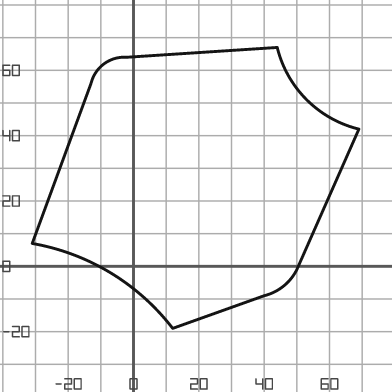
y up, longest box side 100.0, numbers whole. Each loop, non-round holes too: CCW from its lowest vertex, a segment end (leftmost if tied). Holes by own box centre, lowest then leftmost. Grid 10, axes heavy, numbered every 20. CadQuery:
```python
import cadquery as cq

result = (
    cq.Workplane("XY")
    .moveTo(12.0, -19.0)
    .lineTo(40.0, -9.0)
    .threePointArc((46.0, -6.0), (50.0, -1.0))
    .lineTo(69.0, 42.0)
    .threePointArc((53.0, 51.0), (44.0, 67.0))
    .lineTo(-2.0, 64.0)
    .threePointArc((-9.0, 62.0), (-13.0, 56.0))
    .lineTo(-31.0, 7.0)
    .threePointArc((-7.0, -2.0), (12.0, -19.0))
    .close()
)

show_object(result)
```